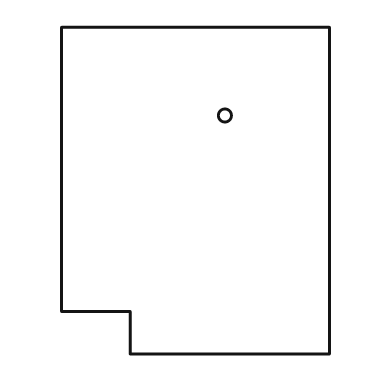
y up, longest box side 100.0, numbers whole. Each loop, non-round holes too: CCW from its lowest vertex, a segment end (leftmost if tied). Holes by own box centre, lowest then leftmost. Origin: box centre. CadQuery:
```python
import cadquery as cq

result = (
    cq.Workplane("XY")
    .moveTo(-20.0, -50.0)
    .lineTo(41.0, -50.0)
    .lineTo(41.0, 50.0)
    .lineTo(-41.0, 50.0)
    .lineTo(-41.0, -37.0)
    .lineTo(-20.0, -37.0)
    .close()
    .moveTo(9.0, 23.0)
    .circle(2.0)
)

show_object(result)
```